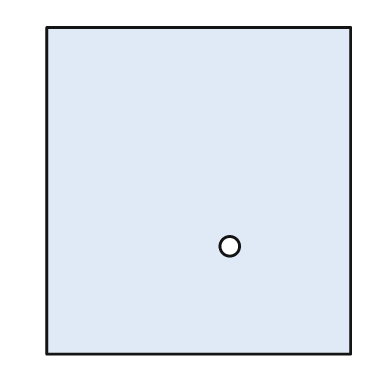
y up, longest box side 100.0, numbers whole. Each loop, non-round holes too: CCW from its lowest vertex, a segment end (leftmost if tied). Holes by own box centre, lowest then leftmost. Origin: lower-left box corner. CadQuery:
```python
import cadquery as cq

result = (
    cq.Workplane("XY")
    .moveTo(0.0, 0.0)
    .lineTo(93.0, 0.0)
    .lineTo(93.0, 100.0)
    .lineTo(0.0, 100.0)
    .close()
    .moveTo(56.0, 33.0)
    .circle(3.0)
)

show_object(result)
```